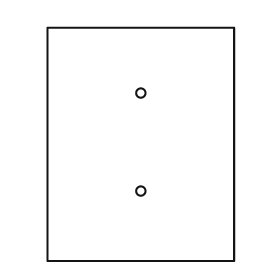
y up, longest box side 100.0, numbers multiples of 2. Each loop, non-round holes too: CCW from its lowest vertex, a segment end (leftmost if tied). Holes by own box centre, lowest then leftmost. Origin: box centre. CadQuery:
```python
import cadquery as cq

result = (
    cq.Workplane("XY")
    .moveTo(-40.0, -50.0)
    .lineTo(40.0, -50.0)
    .lineTo(40.0, 50.0)
    .lineTo(-40.0, 50.0)
    .close()
    .moveTo(0.0, -20.0)
    .circle(2.0)
    .moveTo(0.0, 22.0)
    .circle(2.0)
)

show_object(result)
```